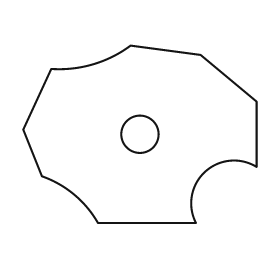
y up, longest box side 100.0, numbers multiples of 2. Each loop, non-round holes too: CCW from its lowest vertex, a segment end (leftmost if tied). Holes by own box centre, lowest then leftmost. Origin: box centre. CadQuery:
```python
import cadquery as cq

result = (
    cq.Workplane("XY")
    .moveTo(-18.0, -38.0)
    .lineTo(24.0, -38.0)
    .threePointArc((28.0, -16.0), (50.0, -14.0))
    .lineTo(50.0, 14.0)
    .lineTo(26.0, 34.0)
    .lineTo(-4.0, 38.0)
    .threePointArc((-20.0, 30.0), (-38.0, 28.0))
    .lineTo(-50.0, 2.0)
    .lineTo(-42.0, -18.0)
    .threePointArc((-28.0, -26.0), (-18.0, -38.0))
    .close()
    .moveTo(0.0, 0.0)
    .circle(8.0)
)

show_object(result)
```